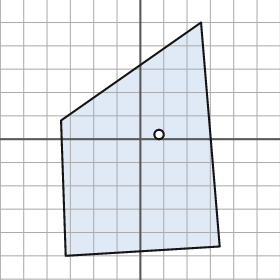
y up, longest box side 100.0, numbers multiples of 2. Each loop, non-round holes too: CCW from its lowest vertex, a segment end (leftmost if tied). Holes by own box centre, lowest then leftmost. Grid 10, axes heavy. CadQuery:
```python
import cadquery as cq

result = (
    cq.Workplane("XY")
    .moveTo(-32.0, -50.0)
    .lineTo(34.0, -46.0)
    .lineTo(26.0, 50.0)
    .lineTo(-34.0, 8.0)
    .close()
    .moveTo(8.0, 2.0)
    .circle(2.0)
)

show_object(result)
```